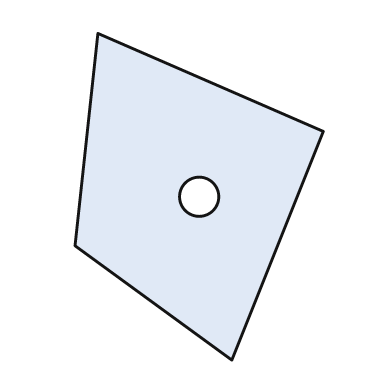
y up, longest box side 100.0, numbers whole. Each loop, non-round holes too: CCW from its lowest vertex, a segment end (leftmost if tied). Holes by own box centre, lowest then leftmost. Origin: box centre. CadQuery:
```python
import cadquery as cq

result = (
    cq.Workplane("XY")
    .moveTo(10.0, -50.0)
    .lineTo(38.0, 20.0)
    .lineTo(-31.0, 50.0)
    .lineTo(-38.0, -15.0)
    .close()
    .moveTo(0.0, 0.0)
    .circle(6.0)
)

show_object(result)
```